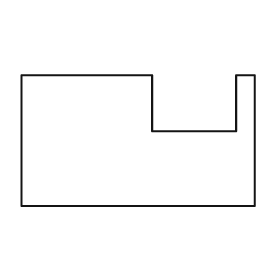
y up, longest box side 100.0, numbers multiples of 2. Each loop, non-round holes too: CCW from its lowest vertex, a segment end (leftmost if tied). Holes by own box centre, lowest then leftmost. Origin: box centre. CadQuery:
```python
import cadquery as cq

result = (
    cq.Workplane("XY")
    .moveTo(-50.0, -28.0)
    .lineTo(50.0, -28.0)
    .lineTo(50.0, 28.0)
    .lineTo(42.0, 28.0)
    .lineTo(42.0, 4.0)
    .lineTo(6.0, 4.0)
    .lineTo(6.0, 28.0)
    .lineTo(-50.0, 28.0)
    .close()
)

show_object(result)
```